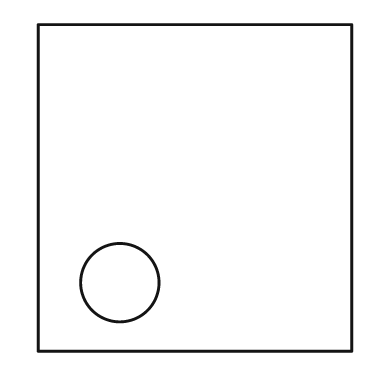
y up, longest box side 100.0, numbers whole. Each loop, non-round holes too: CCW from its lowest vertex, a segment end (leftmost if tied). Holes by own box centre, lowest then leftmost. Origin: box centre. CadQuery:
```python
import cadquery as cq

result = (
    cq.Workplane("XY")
    .moveTo(-48.0, -50.0)
    .lineTo(48.0, -50.0)
    .lineTo(48.0, 50.0)
    .lineTo(-48.0, 50.0)
    .close()
    .moveTo(-23.0, -29.0)
    .circle(12.0)
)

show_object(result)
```